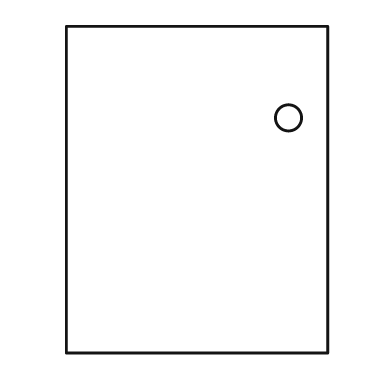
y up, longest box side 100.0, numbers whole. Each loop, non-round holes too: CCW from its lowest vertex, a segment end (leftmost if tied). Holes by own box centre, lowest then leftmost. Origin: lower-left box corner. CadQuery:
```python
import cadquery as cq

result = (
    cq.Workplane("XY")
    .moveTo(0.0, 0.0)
    .lineTo(80.0, 0.0)
    .lineTo(80.0, 100.0)
    .lineTo(0.0, 100.0)
    .close()
    .moveTo(68.0, 72.0)
    .circle(4.0)
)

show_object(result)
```